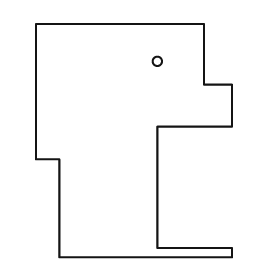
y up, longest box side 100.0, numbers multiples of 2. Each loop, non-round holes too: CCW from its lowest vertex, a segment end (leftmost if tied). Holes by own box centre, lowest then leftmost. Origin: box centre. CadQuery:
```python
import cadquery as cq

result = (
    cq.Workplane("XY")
    .moveTo(-32.0, -50.0)
    .lineTo(42.0, -50.0)
    .lineTo(42.0, -46.0)
    .lineTo(10.0, -46.0)
    .lineTo(10.0, 6.0)
    .lineTo(42.0, 6.0)
    .lineTo(42.0, 24.0)
    .lineTo(30.0, 24.0)
    .lineTo(30.0, 50.0)
    .lineTo(-42.0, 50.0)
    .lineTo(-42.0, -8.0)
    .lineTo(-32.0, -8.0)
    .close()
    .moveTo(10.0, 34.0)
    .circle(2.0)
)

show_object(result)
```